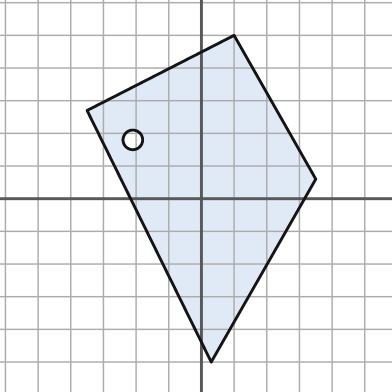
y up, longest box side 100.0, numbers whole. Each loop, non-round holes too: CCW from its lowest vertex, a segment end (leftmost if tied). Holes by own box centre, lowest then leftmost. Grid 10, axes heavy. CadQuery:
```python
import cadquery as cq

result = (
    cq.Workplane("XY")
    .moveTo(3.0, -50.0)
    .lineTo(35.0, 6.0)
    .lineTo(10.0, 50.0)
    .lineTo(-35.0, 27.0)
    .close()
    .moveTo(-21.0, 18.0)
    .circle(3.0)
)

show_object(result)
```